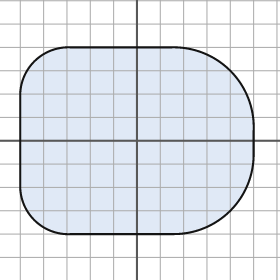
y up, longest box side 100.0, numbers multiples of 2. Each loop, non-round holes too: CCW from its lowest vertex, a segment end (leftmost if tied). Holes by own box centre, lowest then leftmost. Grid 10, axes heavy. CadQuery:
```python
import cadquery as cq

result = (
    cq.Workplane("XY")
    .moveTo(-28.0, -40.0)
    .lineTo(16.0, -40.0)
    .threePointArc((40.0, -30.0), (50.0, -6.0))
    .lineTo(50.0, 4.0)
    .threePointArc((40.0, 30.0), (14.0, 40.0))
    .lineTo(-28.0, 40.0)
    .threePointArc((-44.0, 34.0), (-50.0, 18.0))
    .lineTo(-50.0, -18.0)
    .threePointArc((-44.0, -34.0), (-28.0, -40.0))
    .close()
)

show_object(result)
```